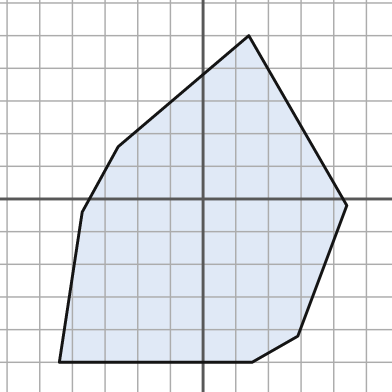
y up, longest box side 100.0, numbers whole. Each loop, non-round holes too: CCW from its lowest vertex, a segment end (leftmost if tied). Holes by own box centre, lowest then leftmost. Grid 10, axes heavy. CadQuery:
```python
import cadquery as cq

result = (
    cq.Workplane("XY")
    .moveTo(-44.0, -50.0)
    .lineTo(15.0, -50.0)
    .lineTo(29.0, -42.0)
    .lineTo(44.0, -2.0)
    .lineTo(14.0, 50.0)
    .lineTo(-26.0, 16.0)
    .lineTo(-37.0, -4.0)
    .close()
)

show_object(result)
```